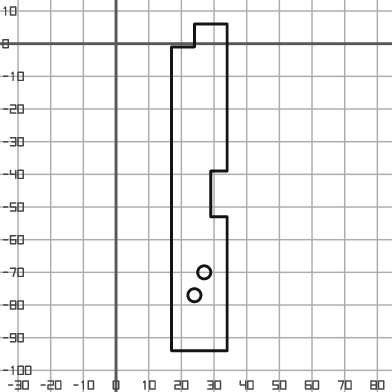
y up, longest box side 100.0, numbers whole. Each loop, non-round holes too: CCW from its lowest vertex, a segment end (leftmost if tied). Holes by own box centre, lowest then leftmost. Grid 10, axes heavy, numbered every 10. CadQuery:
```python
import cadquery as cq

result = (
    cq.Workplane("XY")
    .moveTo(17.0, -94.0)
    .lineTo(34.0, -94.0)
    .lineTo(34.0, -53.0)
    .lineTo(29.0, -53.0)
    .lineTo(29.0, -39.0)
    .lineTo(34.0, -39.0)
    .lineTo(34.0, 6.0)
    .lineTo(24.0, 6.0)
    .lineTo(24.0, -1.0)
    .lineTo(17.0, -1.0)
    .close()
    .moveTo(24.0, -77.0)
    .circle(2.0)
    .moveTo(27.0, -70.0)
    .circle(2.0)
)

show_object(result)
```